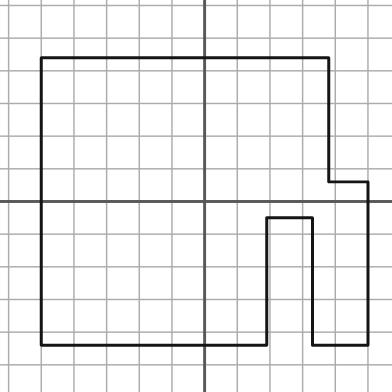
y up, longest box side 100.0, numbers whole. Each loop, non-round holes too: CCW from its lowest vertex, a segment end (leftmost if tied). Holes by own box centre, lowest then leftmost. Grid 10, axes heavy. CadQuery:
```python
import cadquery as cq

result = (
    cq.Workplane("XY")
    .moveTo(-50.0, -44.0)
    .lineTo(19.0, -44.0)
    .lineTo(19.0, -5.0)
    .lineTo(33.0, -5.0)
    .lineTo(33.0, -44.0)
    .lineTo(50.0, -44.0)
    .lineTo(50.0, 6.0)
    .lineTo(38.0, 6.0)
    .lineTo(38.0, 44.0)
    .lineTo(-50.0, 44.0)
    .close()
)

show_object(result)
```